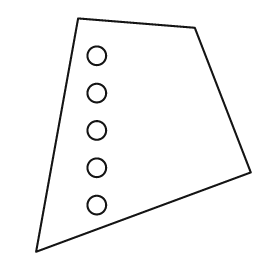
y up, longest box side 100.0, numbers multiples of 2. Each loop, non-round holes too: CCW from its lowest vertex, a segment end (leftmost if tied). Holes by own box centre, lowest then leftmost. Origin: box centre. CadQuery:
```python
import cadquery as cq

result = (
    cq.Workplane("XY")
    .moveTo(-46.0, -50.0)
    .lineTo(46.0, -16.0)
    .lineTo(22.0, 46.0)
    .lineTo(-28.0, 50.0)
    .close()
    .moveTo(-20.0, -30.0)
    .circle(4.0)
    .moveTo(-20.0, -14.0)
    .circle(4.0)
    .moveTo(-20.0, 2.0)
    .circle(4.0)
    .moveTo(-20.0, 18.0)
    .circle(4.0)
    .moveTo(-20.0, 34.0)
    .circle(4.0)
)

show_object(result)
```